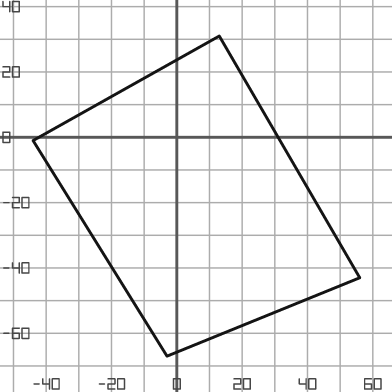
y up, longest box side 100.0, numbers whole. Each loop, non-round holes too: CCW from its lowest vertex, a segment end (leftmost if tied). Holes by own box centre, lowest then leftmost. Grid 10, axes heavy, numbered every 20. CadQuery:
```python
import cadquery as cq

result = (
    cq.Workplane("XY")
    .moveTo(-3.0, -67.0)
    .lineTo(56.0, -43.0)
    .lineTo(13.0, 31.0)
    .lineTo(-44.0, -1.0)
    .close()
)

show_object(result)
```